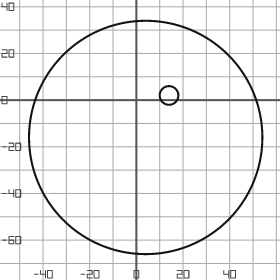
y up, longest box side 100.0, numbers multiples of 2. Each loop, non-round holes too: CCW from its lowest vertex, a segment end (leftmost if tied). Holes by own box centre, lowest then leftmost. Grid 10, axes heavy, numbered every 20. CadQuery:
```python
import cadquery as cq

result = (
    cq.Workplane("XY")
    .moveTo(4.0, -16.0)
    .circle(50.0)
    .moveTo(14.0, 2.0)
    .circle(4.0)
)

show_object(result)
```